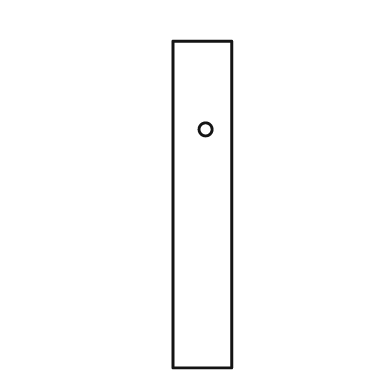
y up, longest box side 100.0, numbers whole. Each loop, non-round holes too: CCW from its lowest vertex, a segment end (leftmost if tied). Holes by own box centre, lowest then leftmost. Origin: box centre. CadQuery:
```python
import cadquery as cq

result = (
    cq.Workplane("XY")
    .moveTo(-9.0, -50.0)
    .lineTo(9.0, -50.0)
    .lineTo(9.0, 50.0)
    .lineTo(-9.0, 50.0)
    .close()
    .moveTo(1.0, 23.0)
    .circle(2.0)
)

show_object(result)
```